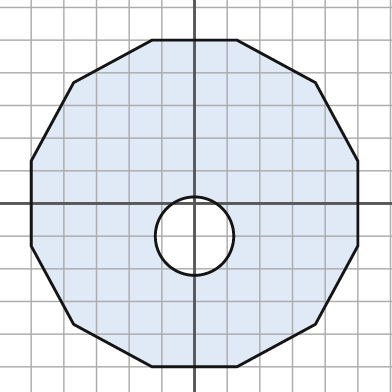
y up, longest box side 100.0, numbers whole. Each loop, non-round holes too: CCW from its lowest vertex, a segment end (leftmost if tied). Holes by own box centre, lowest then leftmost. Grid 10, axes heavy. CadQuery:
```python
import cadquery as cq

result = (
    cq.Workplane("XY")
    .moveTo(-13.0, -50.0)
    .lineTo(13.0, -50.0)
    .lineTo(37.0, -37.0)
    .lineTo(50.0, -13.0)
    .lineTo(50.0, 13.0)
    .lineTo(37.0, 37.0)
    .lineTo(13.0, 50.0)
    .lineTo(-13.0, 50.0)
    .lineTo(-37.0, 37.0)
    .lineTo(-50.0, 13.0)
    .lineTo(-50.0, -13.0)
    .lineTo(-37.0, -37.0)
    .close()
    .moveTo(0.0, -10.0)
    .circle(12.0)
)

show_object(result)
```